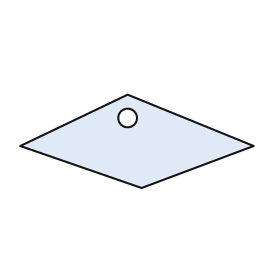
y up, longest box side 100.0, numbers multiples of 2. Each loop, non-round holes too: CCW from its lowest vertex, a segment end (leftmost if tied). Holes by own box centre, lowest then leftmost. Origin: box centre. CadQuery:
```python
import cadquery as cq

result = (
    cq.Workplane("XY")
    .moveTo(2.0, -20.0)
    .lineTo(50.0, -2.0)
    .lineTo(-4.0, 20.0)
    .lineTo(-50.0, -2.0)
    .close()
    .moveTo(-4.0, 10.0)
    .circle(4.0)
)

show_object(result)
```